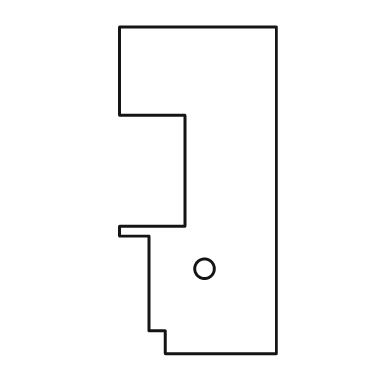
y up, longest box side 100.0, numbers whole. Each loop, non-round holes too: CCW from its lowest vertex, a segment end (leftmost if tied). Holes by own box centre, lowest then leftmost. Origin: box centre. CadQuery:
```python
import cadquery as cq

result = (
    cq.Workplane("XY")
    .moveTo(-10.0, -50.0)
    .lineTo(24.0, -50.0)
    .lineTo(24.0, 50.0)
    .lineTo(-24.0, 50.0)
    .lineTo(-24.0, 23.0)
    .lineTo(-4.0, 23.0)
    .lineTo(-4.0, -11.0)
    .lineTo(-24.0, -11.0)
    .lineTo(-24.0, -14.0)
    .lineTo(-15.0, -14.0)
    .lineTo(-15.0, -43.0)
    .lineTo(-10.0, -43.0)
    .close()
    .moveTo(2.0, -24.0)
    .circle(3.0)
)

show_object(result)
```